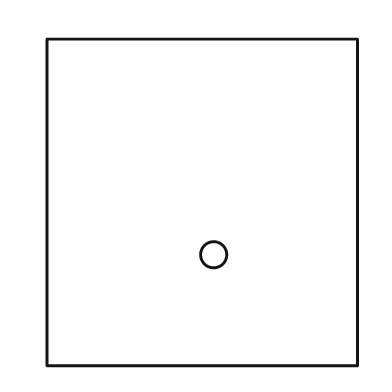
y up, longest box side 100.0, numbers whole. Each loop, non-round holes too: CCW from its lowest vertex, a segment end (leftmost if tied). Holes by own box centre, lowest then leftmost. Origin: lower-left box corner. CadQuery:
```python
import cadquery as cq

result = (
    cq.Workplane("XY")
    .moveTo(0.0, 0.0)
    .lineTo(95.0, 0.0)
    .lineTo(95.0, 100.0)
    .lineTo(0.0, 100.0)
    .close()
    .moveTo(51.0, 34.0)
    .circle(4.0)
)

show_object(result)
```